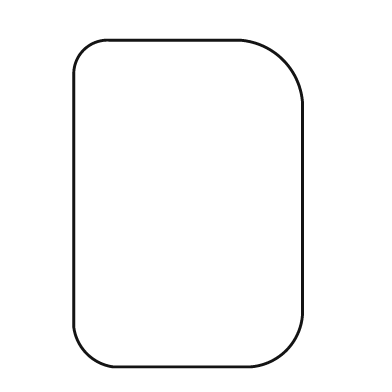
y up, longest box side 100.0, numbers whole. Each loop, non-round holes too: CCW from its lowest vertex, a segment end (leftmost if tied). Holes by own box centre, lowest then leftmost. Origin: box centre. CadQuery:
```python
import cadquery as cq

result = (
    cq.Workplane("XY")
    .moveTo(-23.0, -50.0)
    .lineTo(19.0, -50.0)
    .threePointArc((30.0, -45.0), (35.0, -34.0))
    .lineTo(35.0, 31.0)
    .threePointArc((29.0, 44.0), (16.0, 50.0))
    .lineTo(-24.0, 50.0)
    .threePointArc((-32.0, 47.0), (-35.0, 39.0))
    .lineTo(-35.0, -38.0)
    .threePointArc((-31.0, -46.0), (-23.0, -50.0))
    .close()
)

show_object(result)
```